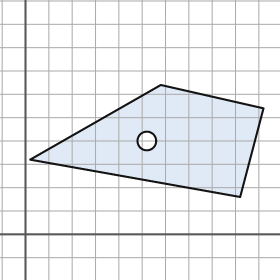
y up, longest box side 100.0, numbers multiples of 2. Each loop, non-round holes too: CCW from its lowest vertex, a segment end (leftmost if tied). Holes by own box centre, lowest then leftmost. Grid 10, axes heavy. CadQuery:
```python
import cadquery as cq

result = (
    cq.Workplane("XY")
    .moveTo(92.0, 16.0)
    .lineTo(102.0, 54.0)
    .lineTo(58.0, 64.0)
    .lineTo(2.0, 32.0)
    .close()
    .moveTo(52.0, 40.0)
    .circle(4.0)
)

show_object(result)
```